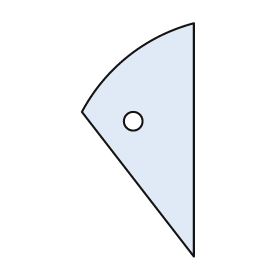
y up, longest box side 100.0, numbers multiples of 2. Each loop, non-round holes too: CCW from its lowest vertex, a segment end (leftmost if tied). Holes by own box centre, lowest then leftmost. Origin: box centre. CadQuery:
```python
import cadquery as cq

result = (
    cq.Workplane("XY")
    .moveTo(24.0, -50.0)
    .lineTo(24.0, 50.0)
    .threePointArc((-4.0, 36.0), (-24.0, 12.0))
    .close()
    .moveTo(-2.0, 8.0)
    .circle(4.0)
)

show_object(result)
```